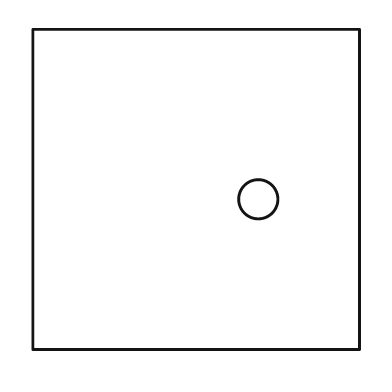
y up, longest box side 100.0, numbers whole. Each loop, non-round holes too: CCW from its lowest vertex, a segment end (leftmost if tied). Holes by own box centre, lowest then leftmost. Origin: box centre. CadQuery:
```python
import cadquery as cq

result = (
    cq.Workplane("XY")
    .moveTo(-50.0, -49.0)
    .lineTo(50.0, -49.0)
    .lineTo(50.0, 49.0)
    .lineTo(-50.0, 49.0)
    .close()
    .moveTo(19.0, -3.0)
    .circle(6.0)
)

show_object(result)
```